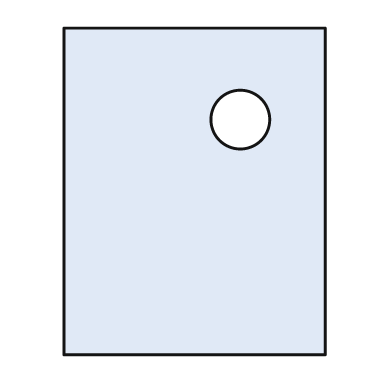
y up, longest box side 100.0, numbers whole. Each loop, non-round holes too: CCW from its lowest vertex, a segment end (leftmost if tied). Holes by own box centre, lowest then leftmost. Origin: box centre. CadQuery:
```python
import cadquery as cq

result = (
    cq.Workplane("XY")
    .moveTo(-40.0, -50.0)
    .lineTo(40.0, -50.0)
    .lineTo(40.0, 50.0)
    .lineTo(-40.0, 50.0)
    .close()
    .moveTo(14.0, 22.0)
    .circle(9.0)
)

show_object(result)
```